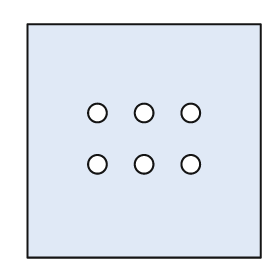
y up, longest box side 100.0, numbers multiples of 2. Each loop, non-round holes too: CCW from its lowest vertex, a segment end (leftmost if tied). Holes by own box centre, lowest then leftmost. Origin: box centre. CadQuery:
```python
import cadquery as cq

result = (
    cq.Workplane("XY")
    .moveTo(-50.0, -50.0)
    .lineTo(50.0, -50.0)
    .lineTo(50.0, 50.0)
    .lineTo(-50.0, 50.0)
    .close()
    .moveTo(-20.0, -10.0)
    .circle(4.0)
    .moveTo(0.0, -10.0)
    .circle(4.0)
    .moveTo(20.0, -10.0)
    .circle(4.0)
    .moveTo(-20.0, 12.0)
    .circle(4.0)
    .moveTo(0.0, 12.0)
    .circle(4.0)
    .moveTo(20.0, 12.0)
    .circle(4.0)
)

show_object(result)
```